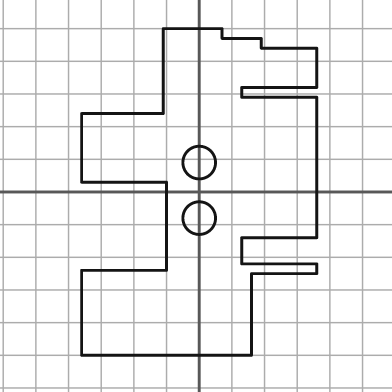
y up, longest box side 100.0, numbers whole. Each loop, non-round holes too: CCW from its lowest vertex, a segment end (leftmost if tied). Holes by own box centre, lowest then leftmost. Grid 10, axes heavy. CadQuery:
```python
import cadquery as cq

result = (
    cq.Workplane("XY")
    .moveTo(-36.0, -50.0)
    .lineTo(16.0, -50.0)
    .lineTo(16.0, -25.0)
    .lineTo(36.0, -25.0)
    .lineTo(36.0, -22.0)
    .lineTo(13.0, -22.0)
    .lineTo(13.0, -14.0)
    .lineTo(36.0, -14.0)
    .lineTo(36.0, 29.0)
    .lineTo(13.0, 29.0)
    .lineTo(13.0, 32.0)
    .lineTo(36.0, 32.0)
    .lineTo(36.0, 44.0)
    .lineTo(19.0, 44.0)
    .lineTo(19.0, 47.0)
    .lineTo(7.0, 47.0)
    .lineTo(7.0, 50.0)
    .lineTo(-11.0, 50.0)
    .lineTo(-11.0, 24.0)
    .lineTo(-36.0, 24.0)
    .lineTo(-36.0, 3.0)
    .lineTo(-10.0, 3.0)
    .lineTo(-10.0, -24.0)
    .lineTo(-36.0, -24.0)
    .close()
    .moveTo(0.0, -8.0)
    .circle(5.0)
    .moveTo(0.0, 9.0)
    .circle(5.0)
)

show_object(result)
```